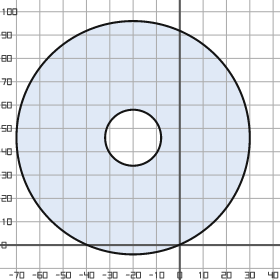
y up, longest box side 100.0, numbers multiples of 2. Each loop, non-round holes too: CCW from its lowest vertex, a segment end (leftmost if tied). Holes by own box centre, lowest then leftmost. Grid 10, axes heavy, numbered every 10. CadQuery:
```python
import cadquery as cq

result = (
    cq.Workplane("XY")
    .moveTo(-20.0, 46.0)
    .circle(50.0)
    .moveTo(-20.0, 46.0)
    .circle(12.0)
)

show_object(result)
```